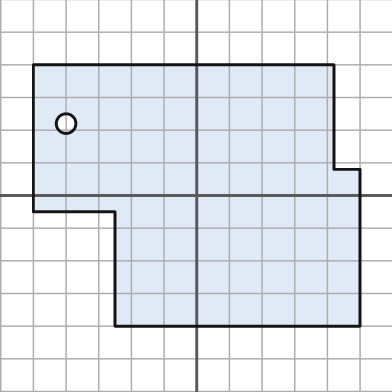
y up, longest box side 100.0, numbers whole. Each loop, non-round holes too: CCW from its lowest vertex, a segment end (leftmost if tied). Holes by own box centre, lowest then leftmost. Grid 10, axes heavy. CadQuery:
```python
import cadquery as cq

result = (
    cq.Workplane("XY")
    .moveTo(-25.0, -40.0)
    .lineTo(50.0, -40.0)
    .lineTo(50.0, 8.0)
    .lineTo(42.0, 8.0)
    .lineTo(42.0, 40.0)
    .lineTo(-50.0, 40.0)
    .lineTo(-50.0, -5.0)
    .lineTo(-25.0, -5.0)
    .close()
    .moveTo(-40.0, 22.0)
    .circle(3.0)
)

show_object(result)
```